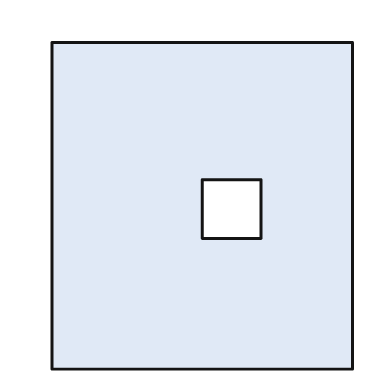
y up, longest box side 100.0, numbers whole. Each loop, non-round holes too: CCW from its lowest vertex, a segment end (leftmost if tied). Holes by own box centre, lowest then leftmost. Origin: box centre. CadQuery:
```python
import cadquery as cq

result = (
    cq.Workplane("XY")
    .moveTo(-46.0, -50.0)
    .lineTo(46.0, -50.0)
    .lineTo(46.0, 50.0)
    .lineTo(-46.0, 50.0)
    .close()
    .moveTo(0.0, -10.0)
    .lineTo(18.0, -10.0)
    .lineTo(18.0, 8.0)
    .lineTo(0.0, 8.0)
    .close()
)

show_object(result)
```